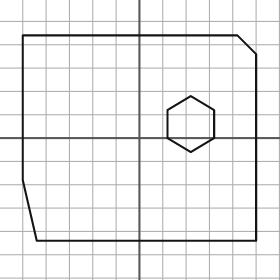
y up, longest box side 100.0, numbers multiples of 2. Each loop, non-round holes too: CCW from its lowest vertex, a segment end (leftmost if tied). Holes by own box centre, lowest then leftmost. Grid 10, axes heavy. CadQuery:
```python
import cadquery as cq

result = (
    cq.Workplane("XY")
    .moveTo(-44.0, -44.0)
    .lineTo(50.0, -44.0)
    .lineTo(50.0, 36.0)
    .lineTo(42.0, 44.0)
    .lineTo(-50.0, 44.0)
    .lineTo(-50.0, -18.0)
    .close()
    .moveTo(22.0, -6.0)
    .lineTo(32.0, 0.0)
    .lineTo(32.0, 12.0)
    .lineTo(22.0, 18.0)
    .lineTo(12.0, 12.0)
    .lineTo(12.0, 0.0)
    .close()
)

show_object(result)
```